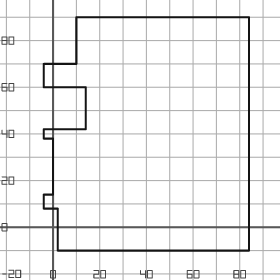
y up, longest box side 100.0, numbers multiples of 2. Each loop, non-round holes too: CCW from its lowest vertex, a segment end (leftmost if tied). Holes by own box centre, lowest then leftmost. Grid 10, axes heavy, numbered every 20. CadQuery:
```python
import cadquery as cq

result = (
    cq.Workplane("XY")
    .moveTo(2.0, -10.0)
    .lineTo(84.0, -10.0)
    .lineTo(84.0, 90.0)
    .lineTo(10.0, 90.0)
    .lineTo(10.0, 70.0)
    .lineTo(-4.0, 70.0)
    .lineTo(-4.0, 60.0)
    .lineTo(14.0, 60.0)
    .lineTo(14.0, 42.0)
    .lineTo(-4.0, 42.0)
    .lineTo(-4.0, 38.0)
    .lineTo(0.0, 38.0)
    .lineTo(0.0, 14.0)
    .lineTo(-4.0, 14.0)
    .lineTo(-4.0, 8.0)
    .lineTo(2.0, 8.0)
    .close()
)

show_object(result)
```